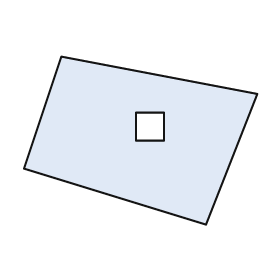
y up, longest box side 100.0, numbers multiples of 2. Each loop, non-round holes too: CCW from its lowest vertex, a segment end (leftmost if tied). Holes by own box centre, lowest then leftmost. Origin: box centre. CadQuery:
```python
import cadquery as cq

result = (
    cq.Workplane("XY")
    .moveTo(28.0, -36.0)
    .lineTo(50.0, 20.0)
    .lineTo(-34.0, 36.0)
    .lineTo(-50.0, -12.0)
    .close()
    .moveTo(-2.0, 0.0)
    .lineTo(10.0, 0.0)
    .lineTo(10.0, 12.0)
    .lineTo(-2.0, 12.0)
    .close()
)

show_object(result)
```